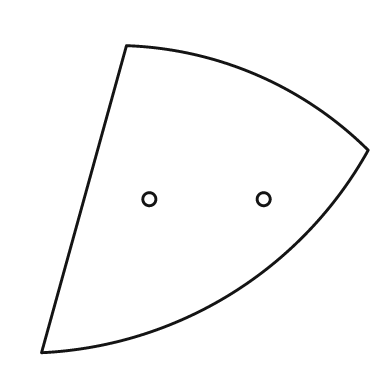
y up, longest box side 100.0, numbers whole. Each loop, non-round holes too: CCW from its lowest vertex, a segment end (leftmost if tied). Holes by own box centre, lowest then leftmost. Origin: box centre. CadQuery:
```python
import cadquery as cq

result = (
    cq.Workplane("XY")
    .moveTo(-50.0, -47.0)
    .threePointArc((8.0, -29.0), (50.0, 15.0))
    .threePointArc((16.0, 38.0), (-24.0, 47.0))
    .close()
    .moveTo(-17.0, 0.0)
    .circle(2.0)
    .moveTo(18.0, 0.0)
    .circle(2.0)
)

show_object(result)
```